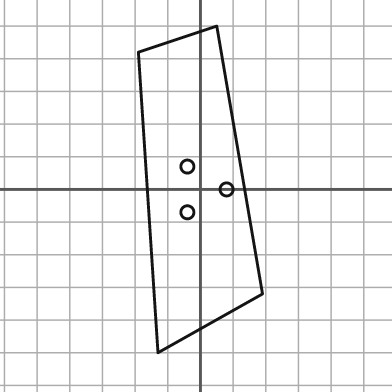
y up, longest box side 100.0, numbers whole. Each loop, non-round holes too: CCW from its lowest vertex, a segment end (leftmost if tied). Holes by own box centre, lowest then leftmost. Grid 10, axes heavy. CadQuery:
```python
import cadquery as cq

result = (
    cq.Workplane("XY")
    .moveTo(-13.0, -50.0)
    .lineTo(19.0, -32.0)
    .lineTo(5.0, 50.0)
    .lineTo(-19.0, 42.0)
    .close()
    .moveTo(-4.0, -7.0)
    .circle(2.0)
    .moveTo(8.0, 0.0)
    .circle(2.0)
    .moveTo(-4.0, 7.0)
    .circle(2.0)
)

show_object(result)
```